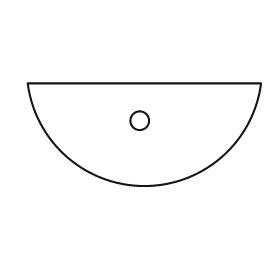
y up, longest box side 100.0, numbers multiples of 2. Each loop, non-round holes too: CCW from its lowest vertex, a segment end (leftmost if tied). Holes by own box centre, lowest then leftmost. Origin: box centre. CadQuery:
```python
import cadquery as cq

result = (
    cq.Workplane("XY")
    .moveTo(-50.0, 22.0)
    .threePointArc((0.0, -22.0), (50.0, 22.0))
    .close()
    .moveTo(-2.0, 6.0)
    .circle(4.0)
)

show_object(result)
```